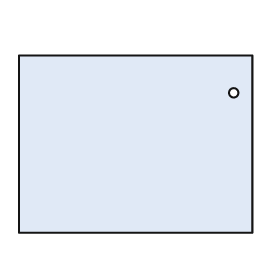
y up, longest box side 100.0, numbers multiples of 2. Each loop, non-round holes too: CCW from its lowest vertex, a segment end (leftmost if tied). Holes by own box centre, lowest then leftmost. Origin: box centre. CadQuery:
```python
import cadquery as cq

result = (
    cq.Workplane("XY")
    .moveTo(-50.0, -38.0)
    .lineTo(50.0, -38.0)
    .lineTo(50.0, 38.0)
    .lineTo(-50.0, 38.0)
    .close()
    .moveTo(42.0, 22.0)
    .circle(2.0)
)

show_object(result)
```